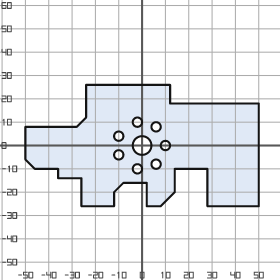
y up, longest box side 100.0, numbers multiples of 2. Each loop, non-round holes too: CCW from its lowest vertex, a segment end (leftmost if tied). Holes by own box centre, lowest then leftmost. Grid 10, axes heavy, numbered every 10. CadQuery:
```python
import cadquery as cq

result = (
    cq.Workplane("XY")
    .moveTo(-26.0, -26.0)
    .lineTo(-12.0, -26.0)
    .lineTo(-12.0, -20.0)
    .lineTo(-8.0, -16.0)
    .lineTo(2.0, -16.0)
    .lineTo(2.0, -26.0)
    .lineTo(8.0, -26.0)
    .lineTo(14.0, -20.0)
    .lineTo(14.0, -10.0)
    .lineTo(28.0, -10.0)
    .lineTo(28.0, -26.0)
    .lineTo(50.0, -26.0)
    .lineTo(50.0, 18.0)
    .lineTo(12.0, 18.0)
    .lineTo(12.0, 26.0)
    .lineTo(-24.0, 26.0)
    .lineTo(-24.0, 12.0)
    .lineTo(-28.0, 8.0)
    .lineTo(-50.0, 8.0)
    .lineTo(-50.0, -6.0)
    .lineTo(-46.0, -10.0)
    .lineTo(-36.0, -10.0)
    .lineTo(-36.0, -14.0)
    .lineTo(-26.0, -14.0)
    .close()
    .moveTo(-2.0, -10.0)
    .circle(2.0)
    .moveTo(6.0, -8.0)
    .circle(2.0)
    .moveTo(-10.0, -4.0)
    .circle(2.0)
    .moveTo(0.0, 0.0)
    .circle(4.0)
    .moveTo(10.0, 0.0)
    .circle(2.0)
    .moveTo(-10.0, 4.0)
    .circle(2.0)
    .moveTo(6.0, 8.0)
    .circle(2.0)
    .moveTo(-2.0, 10.0)
    .circle(2.0)
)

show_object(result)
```